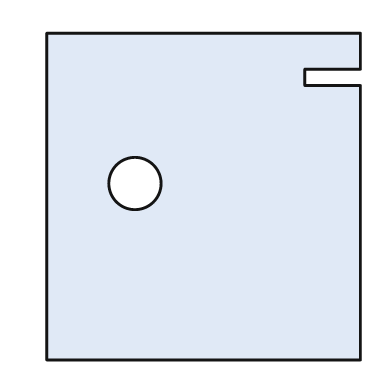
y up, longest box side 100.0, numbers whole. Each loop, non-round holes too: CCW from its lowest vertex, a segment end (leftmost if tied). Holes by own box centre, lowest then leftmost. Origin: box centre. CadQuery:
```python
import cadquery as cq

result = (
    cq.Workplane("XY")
    .moveTo(-48.0, -50.0)
    .lineTo(48.0, -50.0)
    .lineTo(48.0, 34.0)
    .lineTo(31.0, 34.0)
    .lineTo(31.0, 39.0)
    .lineTo(48.0, 39.0)
    .lineTo(48.0, 50.0)
    .lineTo(-48.0, 50.0)
    .close()
    .moveTo(-21.0, 4.0)
    .circle(8.0)
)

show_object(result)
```